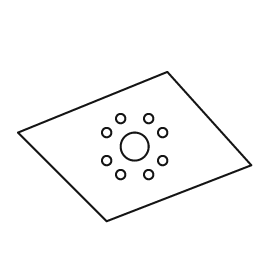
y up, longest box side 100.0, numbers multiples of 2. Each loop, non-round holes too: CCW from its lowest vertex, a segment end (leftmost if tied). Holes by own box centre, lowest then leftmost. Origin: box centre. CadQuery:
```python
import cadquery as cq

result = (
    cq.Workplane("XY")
    .moveTo(-12.0, -32.0)
    .lineTo(50.0, -8.0)
    .lineTo(14.0, 32.0)
    .lineTo(-50.0, 6.0)
    .close()
    .moveTo(-6.0, -12.0)
    .circle(2.0)
    .moveTo(6.0, -12.0)
    .circle(2.0)
    .moveTo(-12.0, -6.0)
    .circle(2.0)
    .moveTo(12.0, -6.0)
    .circle(2.0)
    .moveTo(0.0, 0.0)
    .circle(6.0)
    .moveTo(-12.0, 6.0)
    .circle(2.0)
    .moveTo(12.0, 6.0)
    .circle(2.0)
    .moveTo(-6.0, 12.0)
    .circle(2.0)
    .moveTo(6.0, 12.0)
    .circle(2.0)
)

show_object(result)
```